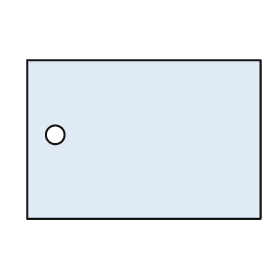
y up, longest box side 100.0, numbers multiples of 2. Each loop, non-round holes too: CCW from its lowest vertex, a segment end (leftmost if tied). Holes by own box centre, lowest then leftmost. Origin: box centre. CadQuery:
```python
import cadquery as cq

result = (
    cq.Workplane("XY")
    .moveTo(-50.0, -34.0)
    .lineTo(50.0, -34.0)
    .lineTo(50.0, 34.0)
    .lineTo(-50.0, 34.0)
    .close()
    .moveTo(-38.0, 2.0)
    .circle(4.0)
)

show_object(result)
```